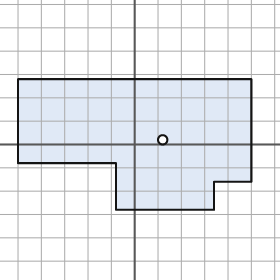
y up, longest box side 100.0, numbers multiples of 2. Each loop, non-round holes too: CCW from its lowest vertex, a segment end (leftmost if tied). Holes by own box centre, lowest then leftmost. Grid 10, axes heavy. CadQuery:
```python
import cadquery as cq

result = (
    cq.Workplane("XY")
    .moveTo(-8.0, -28.0)
    .lineTo(34.0, -28.0)
    .lineTo(34.0, -16.0)
    .lineTo(50.0, -16.0)
    .lineTo(50.0, 28.0)
    .lineTo(-50.0, 28.0)
    .lineTo(-50.0, -8.0)
    .lineTo(-8.0, -8.0)
    .close()
    .moveTo(12.0, 2.0)
    .circle(2.0)
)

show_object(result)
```